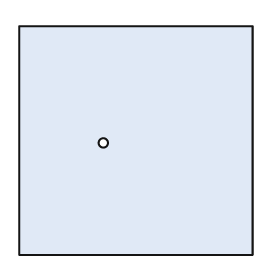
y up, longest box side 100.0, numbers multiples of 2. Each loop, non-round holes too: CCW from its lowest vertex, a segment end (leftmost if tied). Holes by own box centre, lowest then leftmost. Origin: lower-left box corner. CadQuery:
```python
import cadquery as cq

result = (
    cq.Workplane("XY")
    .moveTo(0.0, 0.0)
    .lineTo(100.0, 0.0)
    .lineTo(100.0, 98.0)
    .lineTo(0.0, 98.0)
    .close()
    .moveTo(36.0, 48.0)
    .circle(2.0)
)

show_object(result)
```